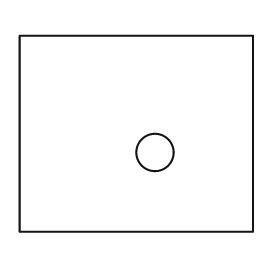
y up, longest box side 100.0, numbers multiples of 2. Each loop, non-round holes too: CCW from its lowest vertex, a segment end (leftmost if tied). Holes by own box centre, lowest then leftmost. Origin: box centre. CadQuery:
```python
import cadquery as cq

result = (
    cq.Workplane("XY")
    .moveTo(-50.0, -42.0)
    .lineTo(50.0, -42.0)
    .lineTo(50.0, 42.0)
    .lineTo(-50.0, 42.0)
    .close()
    .moveTo(8.0, -8.0)
    .circle(8.0)
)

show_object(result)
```